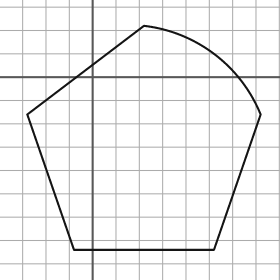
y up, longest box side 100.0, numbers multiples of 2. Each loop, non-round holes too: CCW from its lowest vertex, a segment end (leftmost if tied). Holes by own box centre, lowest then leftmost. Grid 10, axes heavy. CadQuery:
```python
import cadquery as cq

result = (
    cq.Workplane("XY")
    .moveTo(-8.0, -74.0)
    .lineTo(52.0, -74.0)
    .lineTo(72.0, -16.0)
    .threePointArc((52.0, 10.0), (22.0, 22.0))
    .lineTo(-28.0, -16.0)
    .close()
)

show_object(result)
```